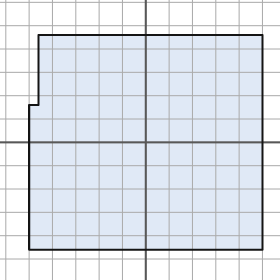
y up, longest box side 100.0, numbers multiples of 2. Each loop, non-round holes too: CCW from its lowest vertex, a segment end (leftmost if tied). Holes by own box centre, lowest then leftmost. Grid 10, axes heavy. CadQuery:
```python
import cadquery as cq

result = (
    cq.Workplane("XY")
    .moveTo(-50.0, -46.0)
    .lineTo(50.0, -46.0)
    .lineTo(50.0, 46.0)
    .lineTo(-46.0, 46.0)
    .lineTo(-46.0, 16.0)
    .lineTo(-50.0, 16.0)
    .close()
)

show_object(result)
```